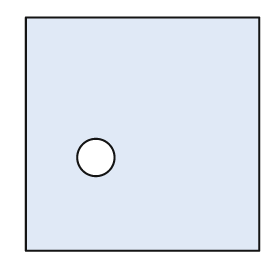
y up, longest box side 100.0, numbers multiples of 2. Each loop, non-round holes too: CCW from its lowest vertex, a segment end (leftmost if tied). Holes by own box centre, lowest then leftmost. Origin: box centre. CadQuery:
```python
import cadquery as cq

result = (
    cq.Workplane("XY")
    .moveTo(-50.0, -50.0)
    .lineTo(50.0, -50.0)
    .lineTo(50.0, 50.0)
    .lineTo(-50.0, 50.0)
    .close()
    .moveTo(-20.0, -10.0)
    .circle(8.0)
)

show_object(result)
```